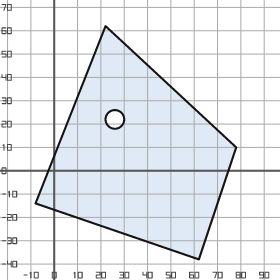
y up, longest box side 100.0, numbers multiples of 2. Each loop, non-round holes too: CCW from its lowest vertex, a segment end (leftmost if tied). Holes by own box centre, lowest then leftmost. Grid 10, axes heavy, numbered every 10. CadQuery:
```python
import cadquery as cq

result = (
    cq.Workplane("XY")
    .moveTo(62.0, -38.0)
    .lineTo(78.0, 10.0)
    .lineTo(22.0, 62.0)
    .lineTo(-8.0, -14.0)
    .close()
    .moveTo(26.0, 22.0)
    .circle(4.0)
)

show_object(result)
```